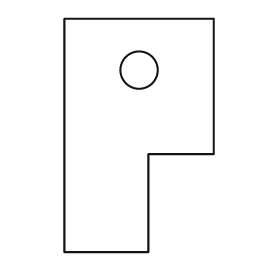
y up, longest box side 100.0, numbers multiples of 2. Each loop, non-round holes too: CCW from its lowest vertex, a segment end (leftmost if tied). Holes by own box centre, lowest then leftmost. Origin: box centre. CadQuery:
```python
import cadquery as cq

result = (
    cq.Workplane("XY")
    .moveTo(-32.0, -50.0)
    .lineTo(4.0, -50.0)
    .lineTo(4.0, -8.0)
    .lineTo(32.0, -8.0)
    .lineTo(32.0, 50.0)
    .lineTo(-32.0, 50.0)
    .close()
    .moveTo(0.0, 28.0)
    .circle(8.0)
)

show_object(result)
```